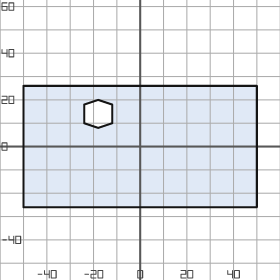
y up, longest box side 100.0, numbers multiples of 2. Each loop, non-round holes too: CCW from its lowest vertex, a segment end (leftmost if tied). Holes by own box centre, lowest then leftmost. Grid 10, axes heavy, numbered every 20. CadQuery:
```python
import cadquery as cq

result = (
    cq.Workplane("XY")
    .moveTo(-50.0, -26.0)
    .lineTo(50.0, -26.0)
    .lineTo(50.0, 26.0)
    .lineTo(-50.0, 26.0)
    .close()
    .moveTo(-18.0, 8.0)
    .lineTo(-12.0, 10.0)
    .lineTo(-12.0, 18.0)
    .lineTo(-18.0, 20.0)
    .lineTo(-24.0, 18.0)
    .lineTo(-24.0, 10.0)
    .close()
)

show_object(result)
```